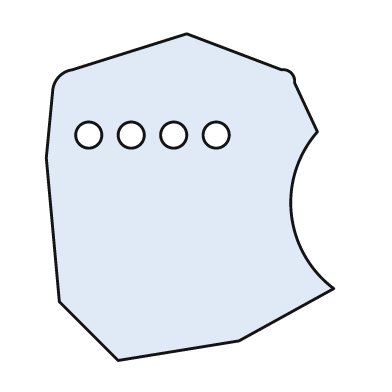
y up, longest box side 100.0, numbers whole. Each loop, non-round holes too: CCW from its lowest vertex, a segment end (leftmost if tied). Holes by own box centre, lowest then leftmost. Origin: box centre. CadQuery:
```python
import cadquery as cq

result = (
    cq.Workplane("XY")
    .moveTo(-22.0, -50.0)
    .lineTo(15.0, -44.0)
    .lineTo(44.0, -28.0)
    .threePointArc((31.0, -5.0), (39.0, 20.0))
    .lineTo(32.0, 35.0)
    .threePointArc((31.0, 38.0), (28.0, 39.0))
    .lineTo(-1.0, 50.0)
    .lineTo(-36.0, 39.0)
    .threePointArc((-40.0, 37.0), (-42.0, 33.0))
    .lineTo(-44.0, 12.0)
    .lineTo(-40.0, -32.0)
    .close()
    .moveTo(-31.0, 19.0)
    .circle(4.0)
    .moveTo(-18.0, 19.0)
    .circle(4.0)
    .moveTo(-5.0, 19.0)
    .circle(4.0)
    .moveTo(8.0, 19.0)
    .circle(4.0)
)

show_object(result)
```